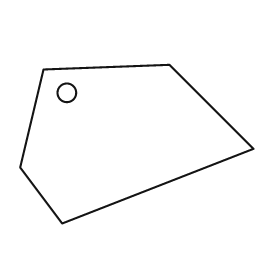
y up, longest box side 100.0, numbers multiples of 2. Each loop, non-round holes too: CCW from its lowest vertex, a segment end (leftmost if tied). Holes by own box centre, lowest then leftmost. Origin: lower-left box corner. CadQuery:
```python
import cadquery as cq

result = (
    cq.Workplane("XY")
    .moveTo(18.0, 0.0)
    .lineTo(100.0, 32.0)
    .lineTo(64.0, 68.0)
    .lineTo(10.0, 66.0)
    .lineTo(0.0, 24.0)
    .close()
    .moveTo(20.0, 56.0)
    .circle(4.0)
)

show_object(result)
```